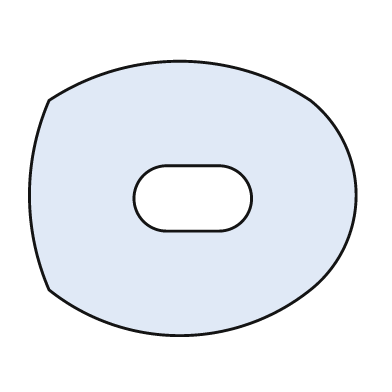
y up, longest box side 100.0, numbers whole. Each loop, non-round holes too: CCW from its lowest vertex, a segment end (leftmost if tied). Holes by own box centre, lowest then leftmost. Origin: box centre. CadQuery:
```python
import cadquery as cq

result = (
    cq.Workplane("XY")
    .moveTo(-44.0, -28.0)
    .threePointArc((-4.0, -42.0), (36.0, -28.0))
    .threePointArc((50.0, 1.0), (36.0, 30.0))
    .threePointArc((-4.0, 42.0), (-44.0, 30.0))
    .threePointArc((-50.0, 1.0), (-44.0, -28.0))
    .close()
    .moveTo(-8.0, -10.0)
    .lineTo(8.0, -10.0)
    .threePointArc((18.0, 0.0), (8.0, 10.0))
    .lineTo(-8.0, 10.0)
    .threePointArc((-18.0, 0.0), (-8.0, -10.0))
    .close()
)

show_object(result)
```